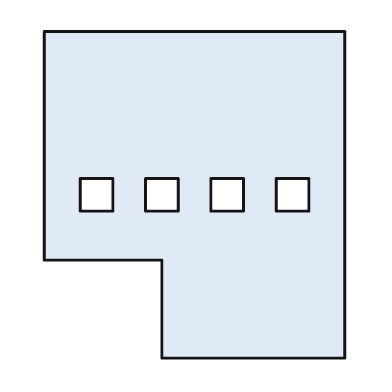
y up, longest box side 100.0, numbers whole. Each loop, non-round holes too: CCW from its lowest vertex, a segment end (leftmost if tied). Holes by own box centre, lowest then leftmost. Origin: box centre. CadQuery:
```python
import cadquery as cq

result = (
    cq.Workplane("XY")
    .moveTo(-10.0, -50.0)
    .lineTo(46.0, -50.0)
    .lineTo(46.0, 50.0)
    .lineTo(-46.0, 50.0)
    .lineTo(-46.0, -20.0)
    .lineTo(-10.0, -20.0)
    .close()
    .moveTo(-35.0, -5.0)
    .lineTo(-25.0, -5.0)
    .lineTo(-25.0, 5.0)
    .lineTo(-35.0, 5.0)
    .close()
    .moveTo(-15.0, -5.0)
    .lineTo(-5.0, -5.0)
    .lineTo(-5.0, 5.0)
    .lineTo(-15.0, 5.0)
    .close()
    .moveTo(5.0, -5.0)
    .lineTo(15.0, -5.0)
    .lineTo(15.0, 5.0)
    .lineTo(5.0, 5.0)
    .close()
    .moveTo(25.0, -5.0)
    .lineTo(35.0, -5.0)
    .lineTo(35.0, 5.0)
    .lineTo(25.0, 5.0)
    .close()
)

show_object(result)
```